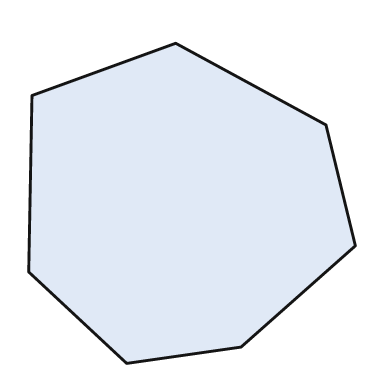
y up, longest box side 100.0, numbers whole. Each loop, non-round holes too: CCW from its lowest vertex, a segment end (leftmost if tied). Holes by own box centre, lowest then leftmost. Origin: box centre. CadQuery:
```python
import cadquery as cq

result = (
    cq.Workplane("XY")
    .moveTo(-20.0, -49.0)
    .lineTo(15.0, -44.0)
    .lineTo(50.0, -13.0)
    .lineTo(41.0, 24.0)
    .lineTo(-5.0, 49.0)
    .lineTo(-49.0, 33.0)
    .lineTo(-50.0, -21.0)
    .close()
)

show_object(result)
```